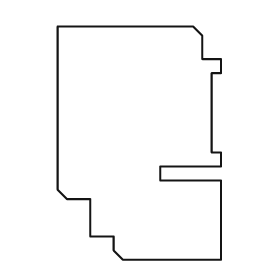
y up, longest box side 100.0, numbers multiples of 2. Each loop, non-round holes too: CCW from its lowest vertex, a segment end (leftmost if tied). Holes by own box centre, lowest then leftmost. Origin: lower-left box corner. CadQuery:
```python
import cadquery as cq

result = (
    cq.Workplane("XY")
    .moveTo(28.0, 0.0)
    .lineTo(70.0, 0.0)
    .lineTo(70.0, 34.0)
    .lineTo(44.0, 34.0)
    .lineTo(44.0, 40.0)
    .lineTo(70.0, 40.0)
    .lineTo(70.0, 46.0)
    .lineTo(66.0, 46.0)
    .lineTo(66.0, 80.0)
    .lineTo(70.0, 80.0)
    .lineTo(70.0, 86.0)
    .lineTo(62.0, 86.0)
    .lineTo(62.0, 96.0)
    .lineTo(58.0, 100.0)
    .lineTo(0.0, 100.0)
    .lineTo(0.0, 30.0)
    .lineTo(4.0, 26.0)
    .lineTo(14.0, 26.0)
    .lineTo(14.0, 10.0)
    .lineTo(24.0, 10.0)
    .lineTo(24.0, 4.0)
    .close()
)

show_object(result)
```